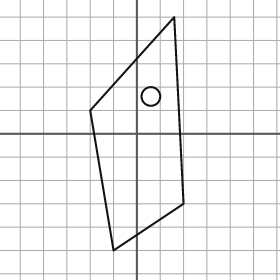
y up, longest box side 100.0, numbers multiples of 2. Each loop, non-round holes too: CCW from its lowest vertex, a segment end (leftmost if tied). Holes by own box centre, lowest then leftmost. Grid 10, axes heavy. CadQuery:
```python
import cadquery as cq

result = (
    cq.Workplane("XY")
    .moveTo(-10.0, -50.0)
    .lineTo(20.0, -30.0)
    .lineTo(16.0, 50.0)
    .lineTo(-20.0, 10.0)
    .close()
    .moveTo(6.0, 16.0)
    .circle(4.0)
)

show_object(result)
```